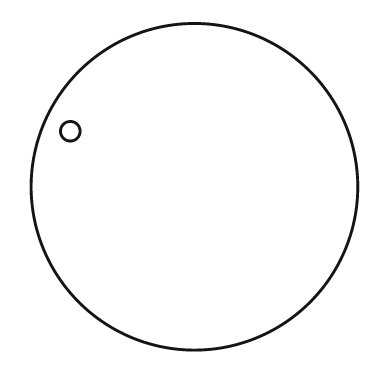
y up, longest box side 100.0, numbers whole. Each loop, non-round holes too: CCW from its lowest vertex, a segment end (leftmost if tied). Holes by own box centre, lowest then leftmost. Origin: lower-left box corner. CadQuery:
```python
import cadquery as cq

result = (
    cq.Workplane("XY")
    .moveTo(50.0, 50.0)
    .circle(50.0)
    .moveTo(12.0, 67.0)
    .circle(3.0)
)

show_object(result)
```